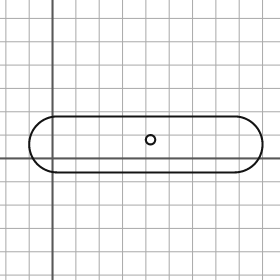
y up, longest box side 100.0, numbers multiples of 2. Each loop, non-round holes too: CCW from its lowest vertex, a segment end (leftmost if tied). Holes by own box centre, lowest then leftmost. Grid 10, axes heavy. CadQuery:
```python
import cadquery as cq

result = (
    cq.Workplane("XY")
    .moveTo(2.0, -6.0)
    .lineTo(78.0, -6.0)
    .threePointArc((90.0, 6.0), (78.0, 18.0))
    .lineTo(2.0, 18.0)
    .threePointArc((-10.0, 6.0), (2.0, -6.0))
    .close()
    .moveTo(42.0, 8.0)
    .circle(2.0)
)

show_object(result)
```